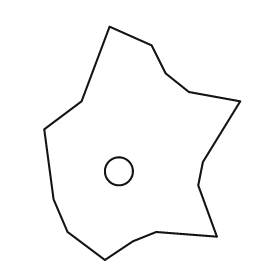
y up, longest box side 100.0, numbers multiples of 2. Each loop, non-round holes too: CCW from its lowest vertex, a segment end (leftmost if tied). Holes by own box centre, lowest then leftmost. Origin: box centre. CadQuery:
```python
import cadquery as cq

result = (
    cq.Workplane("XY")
    .moveTo(-16.0, -50.0)
    .lineTo(-4.0, -42.0)
    .lineTo(6.0, -38.0)
    .lineTo(32.0, -40.0)
    .lineTo(24.0, -18.0)
    .lineTo(26.0, -8.0)
    .lineTo(42.0, 18.0)
    .lineTo(20.0, 22.0)
    .lineTo(10.0, 30.0)
    .lineTo(4.0, 42.0)
    .lineTo(-14.0, 50.0)
    .lineTo(-26.0, 18.0)
    .lineTo(-42.0, 6.0)
    .lineTo(-38.0, -24.0)
    .lineTo(-32.0, -38.0)
    .close()
    .moveTo(-10.0, -12.0)
    .circle(6.0)
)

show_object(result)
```